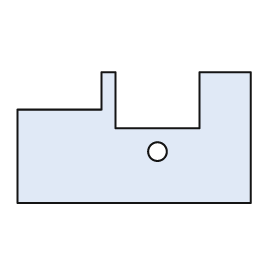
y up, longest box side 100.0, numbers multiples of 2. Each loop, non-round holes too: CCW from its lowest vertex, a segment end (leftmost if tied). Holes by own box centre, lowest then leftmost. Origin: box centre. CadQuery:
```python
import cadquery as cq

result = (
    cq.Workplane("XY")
    .moveTo(-50.0, -28.0)
    .lineTo(50.0, -28.0)
    .lineTo(50.0, 28.0)
    .lineTo(28.0, 28.0)
    .lineTo(28.0, 4.0)
    .lineTo(-8.0, 4.0)
    .lineTo(-8.0, 28.0)
    .lineTo(-14.0, 28.0)
    .lineTo(-14.0, 12.0)
    .lineTo(-50.0, 12.0)
    .close()
    .moveTo(10.0, -6.0)
    .circle(4.0)
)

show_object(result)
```